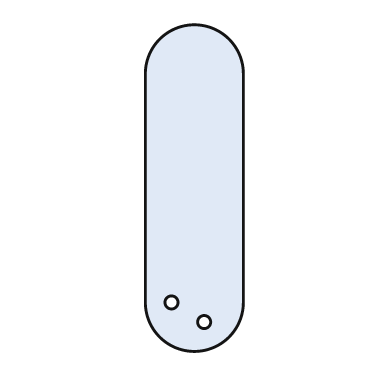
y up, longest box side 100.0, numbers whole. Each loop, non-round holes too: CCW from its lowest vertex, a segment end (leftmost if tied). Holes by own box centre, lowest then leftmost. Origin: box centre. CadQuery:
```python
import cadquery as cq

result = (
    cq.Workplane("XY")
    .moveTo(-15.0, -35.0)
    .threePointArc((0.0, -50.0), (15.0, -35.0))
    .lineTo(15.0, 35.0)
    .threePointArc((0.0, 50.0), (-15.0, 35.0))
    .close()
    .moveTo(3.0, -41.0)
    .circle(2.0)
    .moveTo(-7.0, -35.0)
    .circle(2.0)
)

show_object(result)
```